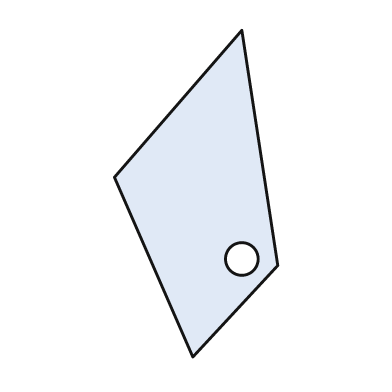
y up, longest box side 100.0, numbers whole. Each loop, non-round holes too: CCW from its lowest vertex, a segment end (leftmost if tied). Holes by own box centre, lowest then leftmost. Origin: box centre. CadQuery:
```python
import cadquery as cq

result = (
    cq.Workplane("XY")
    .moveTo(-1.0, -50.0)
    .lineTo(25.0, -22.0)
    .lineTo(14.0, 50.0)
    .lineTo(-25.0, 5.0)
    .close()
    .moveTo(14.0, -20.0)
    .circle(5.0)
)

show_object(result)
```